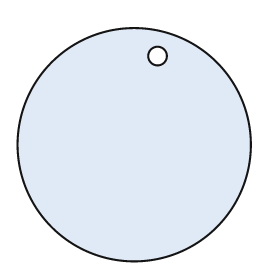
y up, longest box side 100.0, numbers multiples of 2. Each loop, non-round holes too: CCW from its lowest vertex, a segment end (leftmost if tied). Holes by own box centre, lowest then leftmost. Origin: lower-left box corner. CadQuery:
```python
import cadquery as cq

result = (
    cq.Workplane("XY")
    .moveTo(50.0, 50.0)
    .circle(50.0)
    .moveTo(60.0, 88.0)
    .circle(4.0)
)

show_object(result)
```